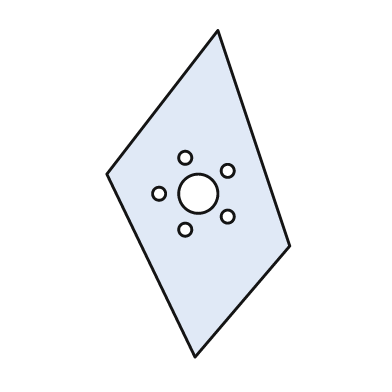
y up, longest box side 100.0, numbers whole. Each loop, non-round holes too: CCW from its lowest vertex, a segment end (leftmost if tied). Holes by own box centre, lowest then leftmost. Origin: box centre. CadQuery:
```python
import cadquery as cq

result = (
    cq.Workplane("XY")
    .moveTo(-1.0, -50.0)
    .lineTo(28.0, -16.0)
    .lineTo(6.0, 50.0)
    .lineTo(-28.0, 6.0)
    .close()
    .moveTo(-4.0, -11.0)
    .circle(2.0)
    .moveTo(9.0, -7.0)
    .circle(2.0)
    .moveTo(-12.0, 0.0)
    .circle(2.0)
    .moveTo(0.0, 0.0)
    .circle(6.0)
    .moveTo(9.0, 7.0)
    .circle(2.0)
    .moveTo(-4.0, 11.0)
    .circle(2.0)
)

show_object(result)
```